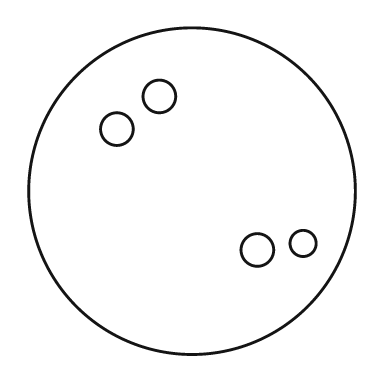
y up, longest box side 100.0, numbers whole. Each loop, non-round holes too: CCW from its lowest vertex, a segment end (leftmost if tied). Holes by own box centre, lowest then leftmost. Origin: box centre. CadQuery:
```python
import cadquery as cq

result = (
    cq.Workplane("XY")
    .moveTo(0.0, 0.0)
    .circle(50.0)
    .moveTo(20.0, -18.0)
    .circle(5.0)
    .moveTo(34.0, -16.0)
    .circle(4.0)
    .moveTo(-23.0, 19.0)
    .circle(5.0)
    .moveTo(-10.0, 29.0)
    .circle(5.0)
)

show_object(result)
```